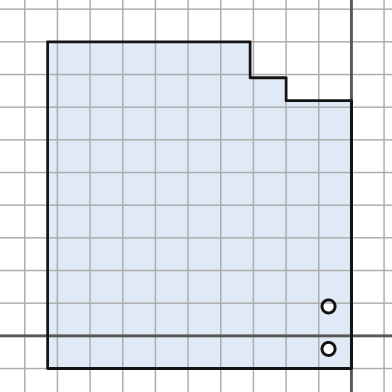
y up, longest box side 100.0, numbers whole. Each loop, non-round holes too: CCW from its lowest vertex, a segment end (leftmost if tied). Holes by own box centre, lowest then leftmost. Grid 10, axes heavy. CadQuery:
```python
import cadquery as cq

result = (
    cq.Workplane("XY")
    .moveTo(-93.0, -10.0)
    .lineTo(0.0, -10.0)
    .lineTo(0.0, 72.0)
    .lineTo(-20.0, 72.0)
    .lineTo(-20.0, 79.0)
    .lineTo(-31.0, 79.0)
    .lineTo(-31.0, 90.0)
    .lineTo(-93.0, 90.0)
    .close()
    .moveTo(-7.0, -4.0)
    .circle(2.0)
    .moveTo(-7.0, 9.0)
    .circle(2.0)
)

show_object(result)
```